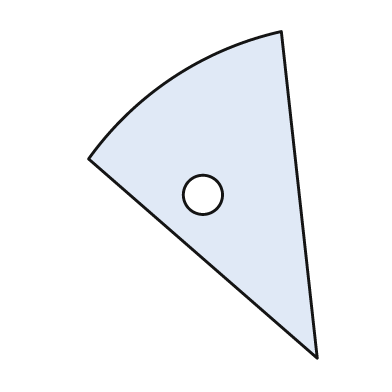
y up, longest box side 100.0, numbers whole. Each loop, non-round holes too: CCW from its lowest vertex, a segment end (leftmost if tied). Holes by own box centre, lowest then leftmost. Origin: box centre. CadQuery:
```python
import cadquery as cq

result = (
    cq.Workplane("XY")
    .moveTo(35.0, -50.0)
    .lineTo(24.0, 50.0)
    .threePointArc((-9.0, 36.0), (-35.0, 11.0))
    .close()
    .moveTo(0.0, 0.0)
    .circle(6.0)
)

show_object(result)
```